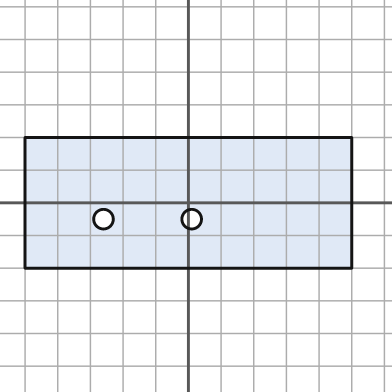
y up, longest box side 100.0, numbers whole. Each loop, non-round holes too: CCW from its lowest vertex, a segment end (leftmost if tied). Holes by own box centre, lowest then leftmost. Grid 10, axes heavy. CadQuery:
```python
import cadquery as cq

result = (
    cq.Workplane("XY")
    .moveTo(-50.0, -20.0)
    .lineTo(50.0, -20.0)
    .lineTo(50.0, 20.0)
    .lineTo(-50.0, 20.0)
    .close()
    .moveTo(-26.0, -5.0)
    .circle(3.0)
    .moveTo(1.0, -5.0)
    .circle(3.0)
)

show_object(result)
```